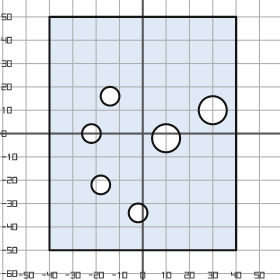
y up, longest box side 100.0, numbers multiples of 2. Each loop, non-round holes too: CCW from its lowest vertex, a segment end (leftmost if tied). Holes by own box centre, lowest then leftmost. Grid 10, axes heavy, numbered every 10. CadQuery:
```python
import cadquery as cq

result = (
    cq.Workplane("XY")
    .moveTo(-40.0, -50.0)
    .lineTo(40.0, -50.0)
    .lineTo(40.0, 50.0)
    .lineTo(-40.0, 50.0)
    .close()
    .moveTo(-2.0, -34.0)
    .circle(4.0)
    .moveTo(-18.0, -22.0)
    .circle(4.0)
    .moveTo(10.0, -2.0)
    .circle(6.0)
    .moveTo(-22.0, 0.0)
    .circle(4.0)
    .moveTo(30.0, 10.0)
    .circle(6.0)
    .moveTo(-14.0, 16.0)
    .circle(4.0)
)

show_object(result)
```